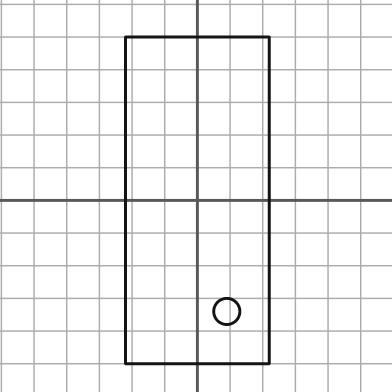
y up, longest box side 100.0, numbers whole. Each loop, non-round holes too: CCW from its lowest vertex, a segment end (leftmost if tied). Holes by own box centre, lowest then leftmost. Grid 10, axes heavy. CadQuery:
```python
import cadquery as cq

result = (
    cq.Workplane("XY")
    .moveTo(-22.0, -50.0)
    .lineTo(22.0, -50.0)
    .lineTo(22.0, 50.0)
    .lineTo(-22.0, 50.0)
    .close()
    .moveTo(9.0, -34.0)
    .circle(4.0)
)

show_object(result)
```